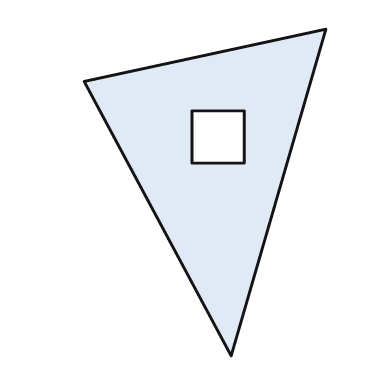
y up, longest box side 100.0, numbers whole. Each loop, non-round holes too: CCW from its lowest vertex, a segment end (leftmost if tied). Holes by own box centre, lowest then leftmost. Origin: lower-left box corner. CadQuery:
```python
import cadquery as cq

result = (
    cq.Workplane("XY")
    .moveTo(45.0, 0.0)
    .lineTo(74.0, 100.0)
    .lineTo(0.0, 84.0)
    .close()
    .moveTo(33.0, 59.0)
    .lineTo(49.0, 59.0)
    .lineTo(49.0, 75.0)
    .lineTo(33.0, 75.0)
    .close()
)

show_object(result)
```